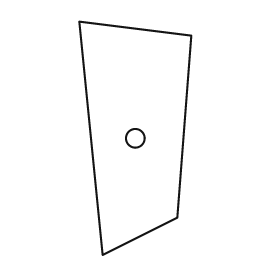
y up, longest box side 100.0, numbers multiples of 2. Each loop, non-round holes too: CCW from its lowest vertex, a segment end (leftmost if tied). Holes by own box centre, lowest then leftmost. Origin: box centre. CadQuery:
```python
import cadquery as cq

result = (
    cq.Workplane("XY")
    .moveTo(-14.0, -50.0)
    .lineTo(18.0, -34.0)
    .lineTo(24.0, 44.0)
    .lineTo(-24.0, 50.0)
    .close()
    .moveTo(0.0, 0.0)
    .circle(4.0)
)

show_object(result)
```